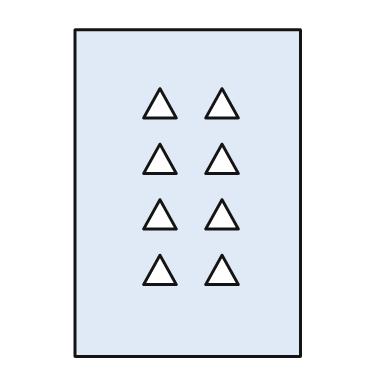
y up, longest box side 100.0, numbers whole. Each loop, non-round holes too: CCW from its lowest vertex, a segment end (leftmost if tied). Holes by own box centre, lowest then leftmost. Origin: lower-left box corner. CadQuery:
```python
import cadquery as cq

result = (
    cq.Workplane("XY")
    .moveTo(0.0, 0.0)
    .lineTo(69.0, 0.0)
    .lineTo(69.0, 100.0)
    .lineTo(0.0, 100.0)
    .close()
    .moveTo(21.0, 22.0)
    .lineTo(31.0, 22.0)
    .lineTo(26.0, 31.0)
    .close()
    .moveTo(40.0, 22.0)
    .lineTo(50.0, 22.0)
    .lineTo(45.0, 31.0)
    .close()
    .moveTo(21.0, 39.0)
    .lineTo(31.0, 39.0)
    .lineTo(26.0, 48.0)
    .close()
    .moveTo(40.0, 39.0)
    .lineTo(50.0, 39.0)
    .lineTo(45.0, 48.0)
    .close()
    .moveTo(21.0, 56.0)
    .lineTo(31.0, 56.0)
    .lineTo(26.0, 65.0)
    .close()
    .moveTo(40.0, 56.0)
    .lineTo(50.0, 56.0)
    .lineTo(45.0, 65.0)
    .close()
    .moveTo(21.0, 73.0)
    .lineTo(31.0, 73.0)
    .lineTo(26.0, 82.0)
    .close()
    .moveTo(40.0, 73.0)
    .lineTo(50.0, 73.0)
    .lineTo(45.0, 82.0)
    .close()
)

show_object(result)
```